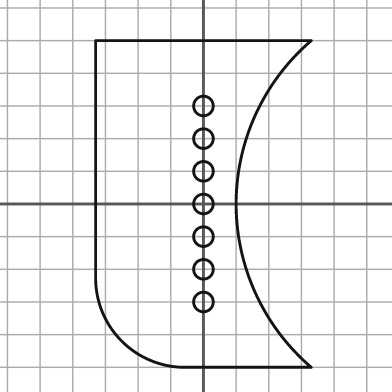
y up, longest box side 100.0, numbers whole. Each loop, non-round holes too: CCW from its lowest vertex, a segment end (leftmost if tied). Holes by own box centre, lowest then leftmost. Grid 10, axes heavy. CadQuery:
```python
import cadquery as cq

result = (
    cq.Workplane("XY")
    .moveTo(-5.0, -50.0)
    .lineTo(33.0, -50.0)
    .threePointArc((10.0, 0.0), (33.0, 50.0))
    .lineTo(-33.0, 50.0)
    .lineTo(-33.0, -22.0)
    .threePointArc((-25.0, -42.0), (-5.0, -50.0))
    .close()
    .moveTo(0.0, -30.0)
    .circle(3.0)
    .moveTo(0.0, -20.0)
    .circle(3.0)
    .moveTo(0.0, -10.0)
    .circle(3.0)
    .moveTo(0.0, 0.0)
    .circle(3.0)
    .moveTo(0.0, 10.0)
    .circle(3.0)
    .moveTo(0.0, 20.0)
    .circle(3.0)
    .moveTo(0.0, 30.0)
    .circle(3.0)
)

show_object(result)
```